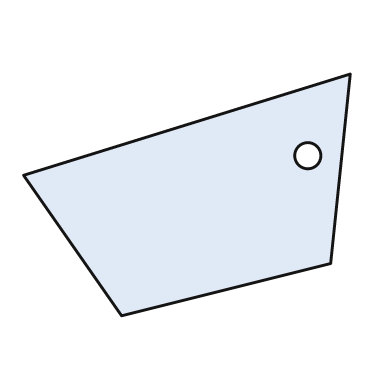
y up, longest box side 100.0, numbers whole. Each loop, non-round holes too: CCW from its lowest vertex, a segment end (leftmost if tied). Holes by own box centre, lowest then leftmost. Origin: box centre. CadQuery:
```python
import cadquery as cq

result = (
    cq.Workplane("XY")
    .moveTo(-20.0, -37.0)
    .lineTo(44.0, -21.0)
    .lineTo(50.0, 37.0)
    .lineTo(-50.0, 6.0)
    .close()
    .moveTo(37.0, 12.0)
    .circle(4.0)
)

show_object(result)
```